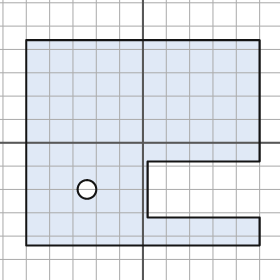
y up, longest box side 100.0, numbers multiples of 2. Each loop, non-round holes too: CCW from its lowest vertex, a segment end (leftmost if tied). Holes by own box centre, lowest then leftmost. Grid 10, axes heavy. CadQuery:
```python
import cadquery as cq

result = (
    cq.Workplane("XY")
    .moveTo(-50.0, -44.0)
    .lineTo(50.0, -44.0)
    .lineTo(50.0, -32.0)
    .lineTo(2.0, -32.0)
    .lineTo(2.0, -8.0)
    .lineTo(50.0, -8.0)
    .lineTo(50.0, 44.0)
    .lineTo(-50.0, 44.0)
    .close()
    .moveTo(-24.0, -20.0)
    .circle(4.0)
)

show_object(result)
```